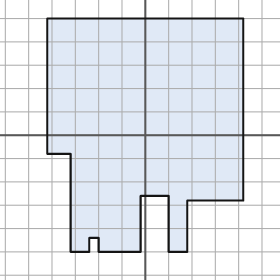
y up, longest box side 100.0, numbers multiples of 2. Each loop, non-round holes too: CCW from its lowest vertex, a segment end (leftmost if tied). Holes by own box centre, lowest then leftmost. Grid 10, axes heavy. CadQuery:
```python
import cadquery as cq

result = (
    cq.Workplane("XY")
    .moveTo(-32.0, -50.0)
    .lineTo(-24.0, -50.0)
    .lineTo(-24.0, -44.0)
    .lineTo(-20.0, -44.0)
    .lineTo(-20.0, -50.0)
    .lineTo(-2.0, -50.0)
    .lineTo(-2.0, -26.0)
    .lineTo(10.0, -26.0)
    .lineTo(10.0, -50.0)
    .lineTo(18.0, -50.0)
    .lineTo(18.0, -28.0)
    .lineTo(42.0, -28.0)
    .lineTo(42.0, 50.0)
    .lineTo(-42.0, 50.0)
    .lineTo(-42.0, -8.0)
    .lineTo(-32.0, -8.0)
    .close()
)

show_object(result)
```